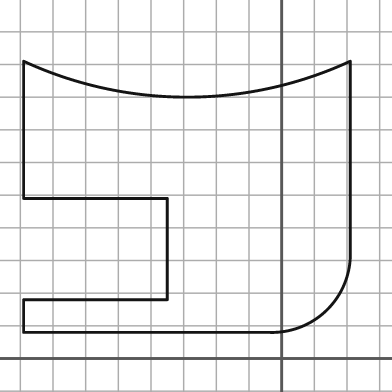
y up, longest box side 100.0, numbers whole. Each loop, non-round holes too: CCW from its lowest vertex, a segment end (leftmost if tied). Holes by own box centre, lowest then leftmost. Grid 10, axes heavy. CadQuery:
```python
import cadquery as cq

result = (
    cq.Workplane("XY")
    .moveTo(-79.0, 8.0)
    .lineTo(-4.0, 8.0)
    .threePointArc((14.0, 15.0), (21.0, 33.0))
    .lineTo(21.0, 91.0)
    .threePointArc((-29.0, 80.0), (-79.0, 91.0))
    .lineTo(-79.0, 49.0)
    .lineTo(-35.0, 49.0)
    .lineTo(-35.0, 18.0)
    .lineTo(-79.0, 18.0)
    .close()
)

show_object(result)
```